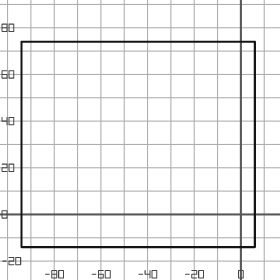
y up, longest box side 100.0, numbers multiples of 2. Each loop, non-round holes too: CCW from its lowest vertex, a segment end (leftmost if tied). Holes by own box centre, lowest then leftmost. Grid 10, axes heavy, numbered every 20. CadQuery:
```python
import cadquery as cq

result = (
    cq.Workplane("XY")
    .moveTo(-94.0, -14.0)
    .lineTo(6.0, -14.0)
    .lineTo(6.0, 74.0)
    .lineTo(-94.0, 74.0)
    .close()
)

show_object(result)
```